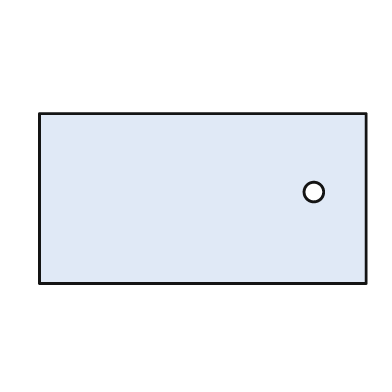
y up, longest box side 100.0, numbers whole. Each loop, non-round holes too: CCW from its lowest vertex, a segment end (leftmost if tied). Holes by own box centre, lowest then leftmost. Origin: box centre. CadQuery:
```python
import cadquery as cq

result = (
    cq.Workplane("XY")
    .moveTo(-50.0, -26.0)
    .lineTo(50.0, -26.0)
    .lineTo(50.0, 26.0)
    .lineTo(-50.0, 26.0)
    .close()
    .moveTo(34.0, 2.0)
    .circle(3.0)
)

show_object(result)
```